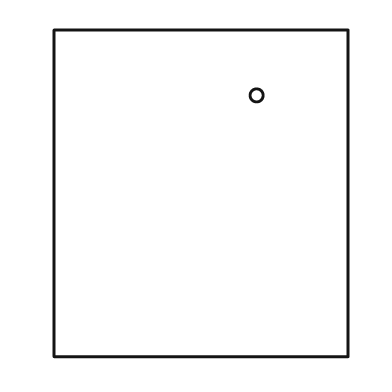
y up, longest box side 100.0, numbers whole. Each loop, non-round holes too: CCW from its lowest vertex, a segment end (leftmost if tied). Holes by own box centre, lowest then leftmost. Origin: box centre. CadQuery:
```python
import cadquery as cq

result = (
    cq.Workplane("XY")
    .moveTo(-45.0, -50.0)
    .lineTo(45.0, -50.0)
    .lineTo(45.0, 50.0)
    .lineTo(-45.0, 50.0)
    .close()
    .moveTo(17.0, 30.0)
    .circle(2.0)
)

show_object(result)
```